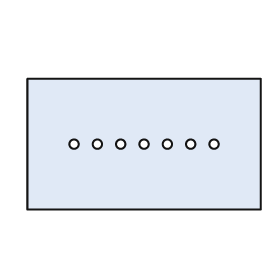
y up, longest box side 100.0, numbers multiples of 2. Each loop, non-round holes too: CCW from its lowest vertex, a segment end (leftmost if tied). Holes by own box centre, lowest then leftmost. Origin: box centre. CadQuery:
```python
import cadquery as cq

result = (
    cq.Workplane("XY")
    .moveTo(-50.0, -28.0)
    .lineTo(50.0, -28.0)
    .lineTo(50.0, 28.0)
    .lineTo(-50.0, 28.0)
    .close()
    .moveTo(-30.0, 0.0)
    .circle(2.0)
    .moveTo(-20.0, 0.0)
    .circle(2.0)
    .moveTo(-10.0, 0.0)
    .circle(2.0)
    .moveTo(0.0, 0.0)
    .circle(2.0)
    .moveTo(10.0, 0.0)
    .circle(2.0)
    .moveTo(20.0, 0.0)
    .circle(2.0)
    .moveTo(30.0, 0.0)
    .circle(2.0)
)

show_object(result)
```